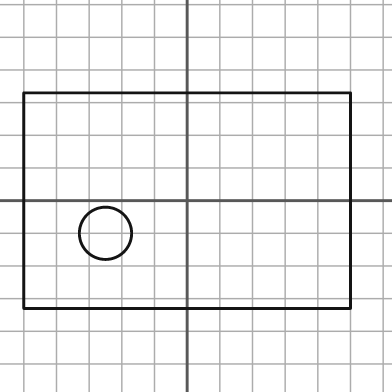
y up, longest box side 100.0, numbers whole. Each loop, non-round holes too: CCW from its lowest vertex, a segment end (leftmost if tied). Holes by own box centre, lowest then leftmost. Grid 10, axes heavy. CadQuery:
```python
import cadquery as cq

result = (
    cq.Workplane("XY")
    .moveTo(-50.0, -33.0)
    .lineTo(50.0, -33.0)
    .lineTo(50.0, 33.0)
    .lineTo(-50.0, 33.0)
    .close()
    .moveTo(-25.0, -10.0)
    .circle(8.0)
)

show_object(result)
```